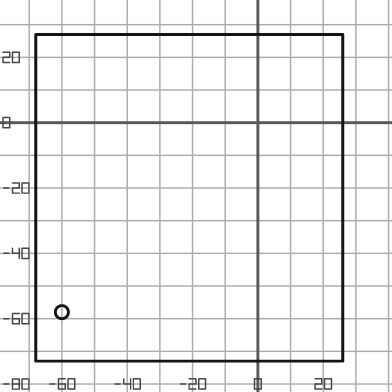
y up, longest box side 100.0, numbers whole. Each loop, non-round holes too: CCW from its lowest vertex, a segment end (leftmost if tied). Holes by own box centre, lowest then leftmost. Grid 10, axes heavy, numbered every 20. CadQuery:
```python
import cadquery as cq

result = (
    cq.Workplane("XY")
    .moveTo(-68.0, -73.0)
    .lineTo(26.0, -73.0)
    .lineTo(26.0, 27.0)
    .lineTo(-68.0, 27.0)
    .close()
    .moveTo(-60.0, -58.0)
    .circle(2.0)
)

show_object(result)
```